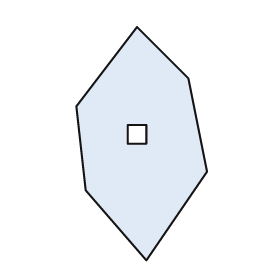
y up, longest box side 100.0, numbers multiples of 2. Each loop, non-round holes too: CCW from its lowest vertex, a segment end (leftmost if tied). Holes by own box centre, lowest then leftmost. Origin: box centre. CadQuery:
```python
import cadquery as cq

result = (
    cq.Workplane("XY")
    .moveTo(2.0, -50.0)
    .lineTo(28.0, -12.0)
    .lineTo(20.0, 28.0)
    .lineTo(-2.0, 50.0)
    .lineTo(-28.0, 16.0)
    .lineTo(-24.0, -20.0)
    .close()
    .moveTo(-6.0, 0.0)
    .lineTo(2.0, 0.0)
    .lineTo(2.0, 8.0)
    .lineTo(-6.0, 8.0)
    .close()
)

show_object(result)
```